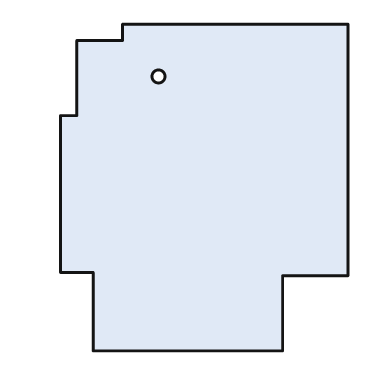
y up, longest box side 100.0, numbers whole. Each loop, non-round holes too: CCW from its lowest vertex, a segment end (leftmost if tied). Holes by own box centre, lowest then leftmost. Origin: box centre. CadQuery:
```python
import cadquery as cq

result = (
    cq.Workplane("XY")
    .moveTo(-34.0, -50.0)
    .lineTo(24.0, -50.0)
    .lineTo(24.0, -27.0)
    .lineTo(44.0, -27.0)
    .lineTo(44.0, 50.0)
    .lineTo(-25.0, 50.0)
    .lineTo(-25.0, 45.0)
    .lineTo(-39.0, 45.0)
    .lineTo(-39.0, 22.0)
    .lineTo(-44.0, 22.0)
    .lineTo(-44.0, -26.0)
    .lineTo(-34.0, -26.0)
    .close()
    .moveTo(-14.0, 34.0)
    .circle(2.0)
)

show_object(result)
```